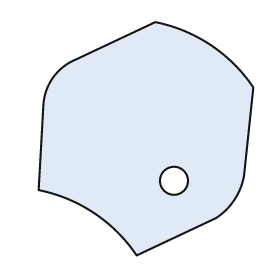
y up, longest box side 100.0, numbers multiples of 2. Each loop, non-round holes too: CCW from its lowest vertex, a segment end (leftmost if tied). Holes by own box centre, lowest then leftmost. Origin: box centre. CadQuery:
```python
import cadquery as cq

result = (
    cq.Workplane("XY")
    .moveTo(-4.0, -50.0)
    .lineTo(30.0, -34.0)
    .threePointArc((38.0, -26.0), (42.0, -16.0))
    .lineTo(46.0, 22.0)
    .threePointArc((28.0, 40.0), (4.0, 50.0))
    .lineTo(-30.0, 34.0)
    .threePointArc((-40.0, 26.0), (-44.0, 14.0))
    .lineTo(-46.0, -22.0)
    .threePointArc((-22.0, -32.0), (-4.0, -50.0))
    .close()
    .moveTo(12.0, -18.0)
    .circle(6.0)
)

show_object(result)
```